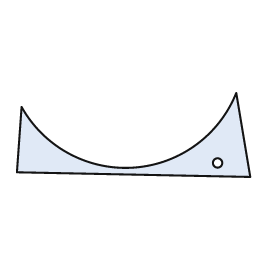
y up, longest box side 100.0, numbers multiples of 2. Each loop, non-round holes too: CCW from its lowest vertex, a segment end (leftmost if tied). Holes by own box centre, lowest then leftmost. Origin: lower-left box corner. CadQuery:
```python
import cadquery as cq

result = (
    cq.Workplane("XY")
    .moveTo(100.0, 0.0)
    .lineTo(94.0, 36.0)
    .threePointArc((50.0, 4.0), (2.0, 30.0))
    .lineTo(0.0, 2.0)
    .close()
    .moveTo(86.0, 6.0)
    .circle(2.0)
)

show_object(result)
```